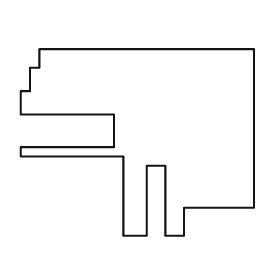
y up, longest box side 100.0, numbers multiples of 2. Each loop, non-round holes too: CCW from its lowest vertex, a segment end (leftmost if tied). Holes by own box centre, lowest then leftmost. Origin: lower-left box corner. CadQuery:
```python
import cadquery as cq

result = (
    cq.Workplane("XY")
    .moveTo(44.0, 0.0)
    .lineTo(54.0, 0.0)
    .lineTo(54.0, 30.0)
    .lineTo(62.0, 30.0)
    .lineTo(62.0, 0.0)
    .lineTo(70.0, 0.0)
    .lineTo(70.0, 12.0)
    .lineTo(100.0, 12.0)
    .lineTo(100.0, 80.0)
    .lineTo(8.0, 80.0)
    .lineTo(8.0, 72.0)
    .lineTo(4.0, 72.0)
    .lineTo(4.0, 62.0)
    .lineTo(0.0, 62.0)
    .lineTo(0.0, 52.0)
    .lineTo(40.0, 52.0)
    .lineTo(40.0, 38.0)
    .lineTo(0.0, 38.0)
    .lineTo(0.0, 34.0)
    .lineTo(44.0, 34.0)
    .close()
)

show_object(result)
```